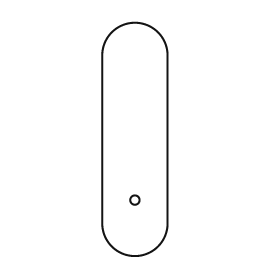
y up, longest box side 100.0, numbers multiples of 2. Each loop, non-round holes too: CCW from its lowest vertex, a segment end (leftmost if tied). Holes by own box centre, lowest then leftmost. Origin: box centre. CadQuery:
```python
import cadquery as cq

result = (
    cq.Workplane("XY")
    .moveTo(-14.0, -36.0)
    .threePointArc((0.0, -50.0), (14.0, -36.0))
    .lineTo(14.0, 36.0)
    .threePointArc((0.0, 50.0), (-14.0, 36.0))
    .close()
    .moveTo(0.0, -26.0)
    .circle(2.0)
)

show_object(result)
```